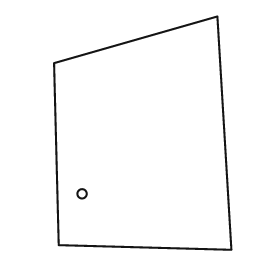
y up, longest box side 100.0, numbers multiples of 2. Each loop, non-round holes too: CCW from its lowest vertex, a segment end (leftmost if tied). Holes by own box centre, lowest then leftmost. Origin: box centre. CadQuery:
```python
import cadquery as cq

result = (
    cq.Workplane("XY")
    .moveTo(38.0, -50.0)
    .lineTo(32.0, 50.0)
    .lineTo(-38.0, 30.0)
    .lineTo(-36.0, -48.0)
    .close()
    .moveTo(-26.0, -26.0)
    .circle(2.0)
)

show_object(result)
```